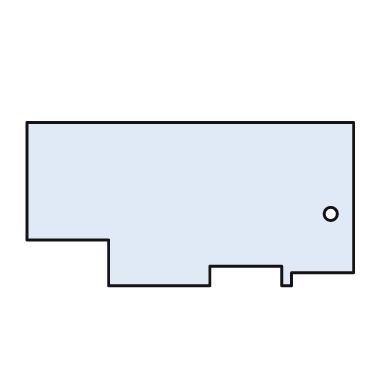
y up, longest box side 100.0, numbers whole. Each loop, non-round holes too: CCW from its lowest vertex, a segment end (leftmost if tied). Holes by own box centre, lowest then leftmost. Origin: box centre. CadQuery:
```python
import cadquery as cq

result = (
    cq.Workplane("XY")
    .moveTo(-25.0, -25.0)
    .lineTo(6.0, -25.0)
    .lineTo(6.0, -19.0)
    .lineTo(28.0, -19.0)
    .lineTo(28.0, -25.0)
    .lineTo(31.0, -25.0)
    .lineTo(31.0, -21.0)
    .lineTo(50.0, -21.0)
    .lineTo(50.0, 25.0)
    .lineTo(-50.0, 25.0)
    .lineTo(-50.0, -11.0)
    .lineTo(-25.0, -11.0)
    .close()
    .moveTo(43.0, -3.0)
    .circle(2.0)
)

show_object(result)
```